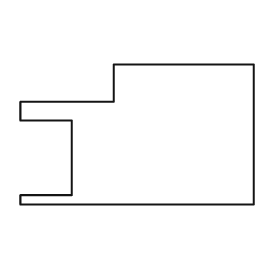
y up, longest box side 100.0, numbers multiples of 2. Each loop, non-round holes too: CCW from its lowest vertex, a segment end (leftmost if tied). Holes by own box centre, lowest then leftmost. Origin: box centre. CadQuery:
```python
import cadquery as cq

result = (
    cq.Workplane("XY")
    .moveTo(-50.0, -30.0)
    .lineTo(50.0, -30.0)
    .lineTo(50.0, 30.0)
    .lineTo(-10.0, 30.0)
    .lineTo(-10.0, 14.0)
    .lineTo(-50.0, 14.0)
    .lineTo(-50.0, 6.0)
    .lineTo(-28.0, 6.0)
    .lineTo(-28.0, -26.0)
    .lineTo(-50.0, -26.0)
    .close()
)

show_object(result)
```